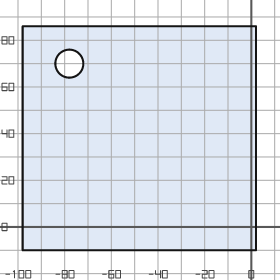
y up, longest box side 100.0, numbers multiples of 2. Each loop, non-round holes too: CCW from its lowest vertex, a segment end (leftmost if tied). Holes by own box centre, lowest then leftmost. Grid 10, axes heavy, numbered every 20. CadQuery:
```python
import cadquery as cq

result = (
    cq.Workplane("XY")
    .moveTo(-98.0, -10.0)
    .lineTo(2.0, -10.0)
    .lineTo(2.0, 86.0)
    .lineTo(-98.0, 86.0)
    .close()
    .moveTo(-78.0, 70.0)
    .circle(6.0)
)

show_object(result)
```